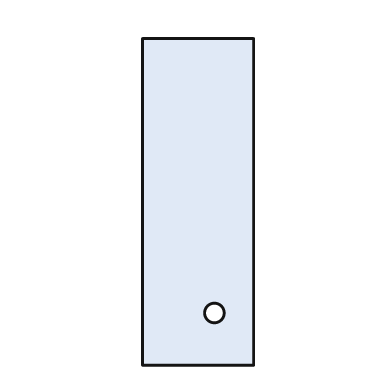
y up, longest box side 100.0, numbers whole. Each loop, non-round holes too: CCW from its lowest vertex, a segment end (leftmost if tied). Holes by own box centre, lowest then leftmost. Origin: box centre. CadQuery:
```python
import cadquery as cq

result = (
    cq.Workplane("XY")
    .moveTo(-17.0, -50.0)
    .lineTo(17.0, -50.0)
    .lineTo(17.0, 50.0)
    .lineTo(-17.0, 50.0)
    .close()
    .moveTo(5.0, -34.0)
    .circle(3.0)
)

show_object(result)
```